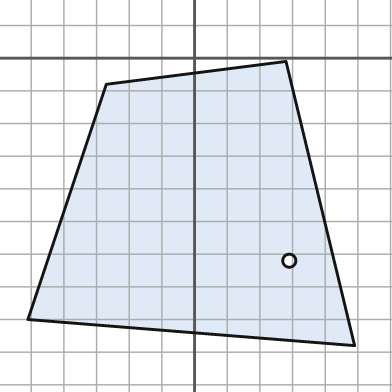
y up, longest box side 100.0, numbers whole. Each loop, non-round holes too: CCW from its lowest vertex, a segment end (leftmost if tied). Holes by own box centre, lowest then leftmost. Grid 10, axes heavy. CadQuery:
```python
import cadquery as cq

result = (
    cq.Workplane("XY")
    .moveTo(49.0, -88.0)
    .lineTo(28.0, -1.0)
    .lineTo(-27.0, -8.0)
    .lineTo(-51.0, -80.0)
    .close()
    .moveTo(29.0, -62.0)
    .circle(2.0)
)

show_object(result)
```